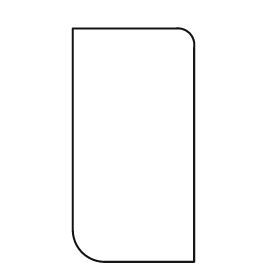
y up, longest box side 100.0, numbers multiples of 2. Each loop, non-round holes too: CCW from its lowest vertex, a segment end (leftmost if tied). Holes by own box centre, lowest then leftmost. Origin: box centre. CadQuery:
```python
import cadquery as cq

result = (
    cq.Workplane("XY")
    .moveTo(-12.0, -50.0)
    .lineTo(26.0, -50.0)
    .lineTo(26.0, 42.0)
    .threePointArc((24.0, 48.0), (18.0, 50.0))
    .lineTo(-26.0, 50.0)
    .lineTo(-26.0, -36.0)
    .threePointArc((-22.0, -46.0), (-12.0, -50.0))
    .close()
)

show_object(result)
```